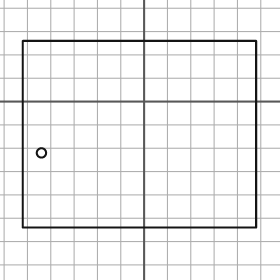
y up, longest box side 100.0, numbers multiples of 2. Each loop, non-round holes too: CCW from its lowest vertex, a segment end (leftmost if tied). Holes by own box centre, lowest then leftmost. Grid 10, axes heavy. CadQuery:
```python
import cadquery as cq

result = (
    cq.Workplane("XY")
    .moveTo(-52.0, -54.0)
    .lineTo(48.0, -54.0)
    .lineTo(48.0, 26.0)
    .lineTo(-52.0, 26.0)
    .close()
    .moveTo(-44.0, -22.0)
    .circle(2.0)
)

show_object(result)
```